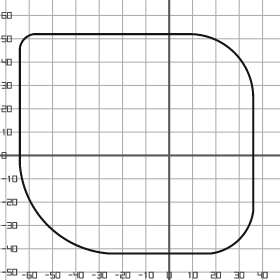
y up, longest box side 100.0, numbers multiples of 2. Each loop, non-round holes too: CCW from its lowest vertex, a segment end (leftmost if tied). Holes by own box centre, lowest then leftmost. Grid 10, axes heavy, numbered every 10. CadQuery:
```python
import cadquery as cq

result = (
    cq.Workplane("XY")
    .moveTo(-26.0, -42.0)
    .lineTo(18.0, -42.0)
    .threePointArc((30.0, -36.0), (36.0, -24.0))
    .lineTo(36.0, 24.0)
    .threePointArc((28.0, 44.0), (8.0, 52.0))
    .lineTo(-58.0, 52.0)
    .threePointArc((-62.0, 50.0), (-64.0, 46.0))
    .lineTo(-64.0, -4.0)
    .threePointArc((-52.0, -30.0), (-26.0, -42.0))
    .close()
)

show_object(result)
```